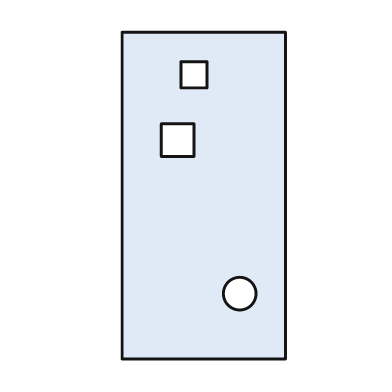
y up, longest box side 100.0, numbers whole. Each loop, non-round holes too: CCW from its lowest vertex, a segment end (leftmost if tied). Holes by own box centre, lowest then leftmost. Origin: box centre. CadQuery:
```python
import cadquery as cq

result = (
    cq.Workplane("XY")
    .moveTo(-25.0, -50.0)
    .lineTo(25.0, -50.0)
    .lineTo(25.0, 50.0)
    .lineTo(-25.0, 50.0)
    .close()
    .moveTo(11.0, -30.0)
    .circle(5.0)
    .moveTo(-13.0, 12.0)
    .lineTo(-3.0, 12.0)
    .lineTo(-3.0, 22.0)
    .lineTo(-13.0, 22.0)
    .close()
    .moveTo(-7.0, 33.0)
    .lineTo(1.0, 33.0)
    .lineTo(1.0, 41.0)
    .lineTo(-7.0, 41.0)
    .close()
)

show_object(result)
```